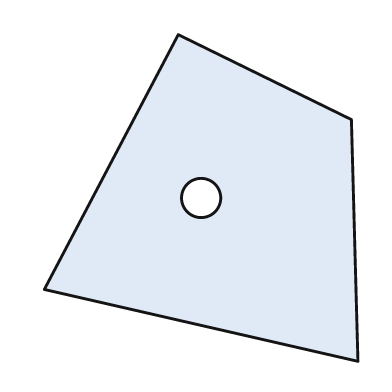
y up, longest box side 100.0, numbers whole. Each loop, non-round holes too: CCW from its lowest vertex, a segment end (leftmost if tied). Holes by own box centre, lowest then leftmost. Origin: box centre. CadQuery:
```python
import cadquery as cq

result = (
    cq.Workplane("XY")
    .moveTo(48.0, -50.0)
    .lineTo(46.0, 24.0)
    .lineTo(-7.0, 50.0)
    .lineTo(-48.0, -28.0)
    .close()
    .moveTo(0.0, 0.0)
    .circle(6.0)
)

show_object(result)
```